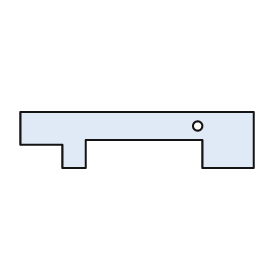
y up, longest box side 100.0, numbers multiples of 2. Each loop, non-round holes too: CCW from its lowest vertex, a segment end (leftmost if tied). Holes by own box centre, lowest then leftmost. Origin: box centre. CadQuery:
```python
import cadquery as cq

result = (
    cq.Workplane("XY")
    .moveTo(-32.0, -12.0)
    .lineTo(-22.0, -12.0)
    .lineTo(-22.0, 0.0)
    .lineTo(28.0, 0.0)
    .lineTo(28.0, -12.0)
    .lineTo(50.0, -12.0)
    .lineTo(50.0, 12.0)
    .lineTo(-50.0, 12.0)
    .lineTo(-50.0, -2.0)
    .lineTo(-32.0, -2.0)
    .close()
    .moveTo(26.0, 6.0)
    .circle(2.0)
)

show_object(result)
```